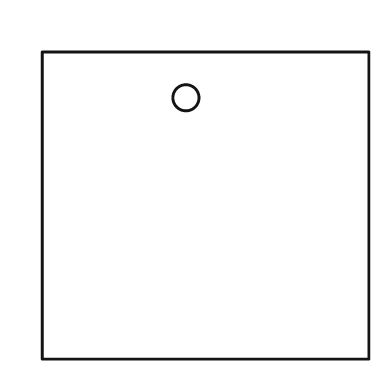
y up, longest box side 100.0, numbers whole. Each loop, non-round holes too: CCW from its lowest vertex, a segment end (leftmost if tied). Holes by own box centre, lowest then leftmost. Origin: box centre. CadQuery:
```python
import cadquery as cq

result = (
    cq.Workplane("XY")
    .moveTo(-50.0, -47.0)
    .lineTo(50.0, -47.0)
    .lineTo(50.0, 47.0)
    .lineTo(-50.0, 47.0)
    .close()
    .moveTo(-6.0, 33.0)
    .circle(4.0)
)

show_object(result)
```